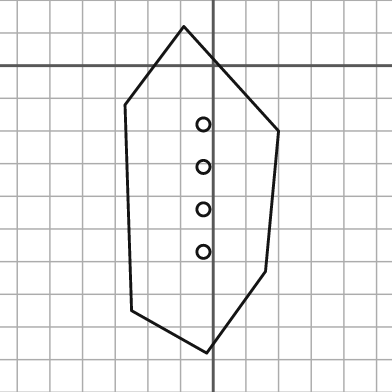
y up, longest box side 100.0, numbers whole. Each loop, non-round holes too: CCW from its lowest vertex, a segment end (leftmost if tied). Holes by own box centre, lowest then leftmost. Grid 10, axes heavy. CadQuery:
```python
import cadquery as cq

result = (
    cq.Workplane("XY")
    .moveTo(-2.0, -88.0)
    .lineTo(16.0, -63.0)
    .lineTo(20.0, -20.0)
    .lineTo(-9.0, 12.0)
    .lineTo(-27.0, -12.0)
    .lineTo(-25.0, -75.0)
    .close()
    .moveTo(-3.0, -57.0)
    .circle(2.0)
    .moveTo(-3.0, -44.0)
    .circle(2.0)
    .moveTo(-3.0, -31.0)
    .circle(2.0)
    .moveTo(-3.0, -18.0)
    .circle(2.0)
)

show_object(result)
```